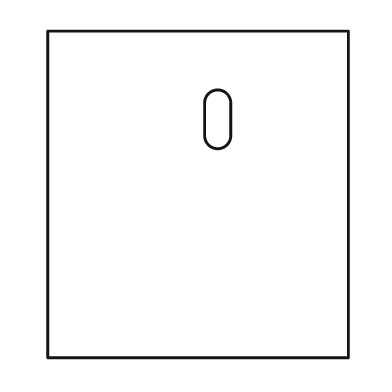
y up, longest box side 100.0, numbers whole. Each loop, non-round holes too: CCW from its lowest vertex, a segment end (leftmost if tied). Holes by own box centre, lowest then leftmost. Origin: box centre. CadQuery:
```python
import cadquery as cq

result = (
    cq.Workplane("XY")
    .moveTo(-46.0, -50.0)
    .lineTo(46.0, -50.0)
    .lineTo(46.0, 50.0)
    .lineTo(-46.0, 50.0)
    .close()
    .moveTo(2.0, 18.0)
    .threePointArc((6.0, 14.0), (10.0, 18.0))
    .lineTo(10.0, 28.0)
    .threePointArc((6.0, 32.0), (2.0, 28.0))
    .close()
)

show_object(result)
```